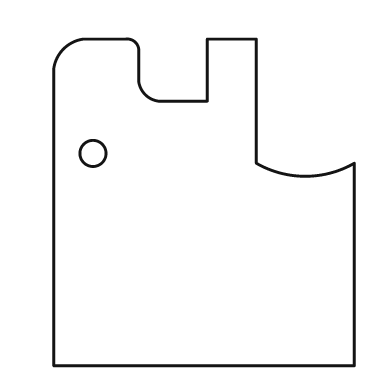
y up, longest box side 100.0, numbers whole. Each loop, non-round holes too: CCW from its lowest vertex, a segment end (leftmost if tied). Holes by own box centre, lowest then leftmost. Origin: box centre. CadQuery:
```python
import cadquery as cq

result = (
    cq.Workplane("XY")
    .moveTo(-46.0, -50.0)
    .lineTo(46.0, -50.0)
    .lineTo(46.0, 12.0)
    .threePointArc((31.0, 8.0), (16.0, 12.0))
    .lineTo(16.0, 50.0)
    .lineTo(1.0, 50.0)
    .lineTo(1.0, 31.0)
    .lineTo(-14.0, 31.0)
    .threePointArc((-18.0, 33.0), (-20.0, 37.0))
    .lineTo(-20.0, 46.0)
    .threePointArc((-21.0, 49.0), (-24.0, 50.0))
    .lineTo(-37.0, 50.0)
    .threePointArc((-43.0, 47.0), (-46.0, 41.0))
    .close()
    .moveTo(-34.0, 15.0)
    .circle(4.0)
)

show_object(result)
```